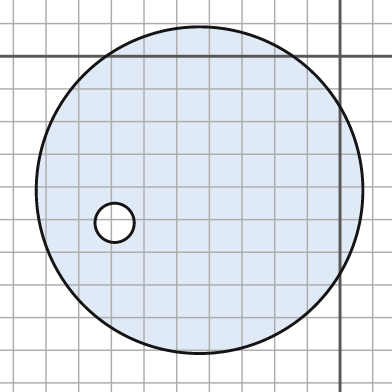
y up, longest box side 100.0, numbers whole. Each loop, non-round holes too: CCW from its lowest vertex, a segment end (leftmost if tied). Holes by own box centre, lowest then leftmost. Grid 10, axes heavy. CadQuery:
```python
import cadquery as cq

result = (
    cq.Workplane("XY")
    .moveTo(-43.0, -41.0)
    .circle(50.0)
    .moveTo(-69.0, -51.0)
    .circle(6.0)
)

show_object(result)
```